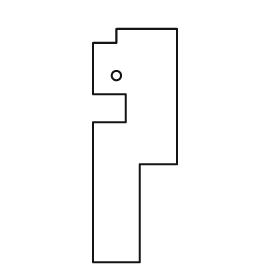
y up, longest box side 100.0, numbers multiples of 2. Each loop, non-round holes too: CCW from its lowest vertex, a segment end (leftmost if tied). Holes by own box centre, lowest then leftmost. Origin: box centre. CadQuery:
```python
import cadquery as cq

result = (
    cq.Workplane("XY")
    .moveTo(-18.0, -50.0)
    .lineTo(2.0, -50.0)
    .lineTo(2.0, -8.0)
    .lineTo(18.0, -8.0)
    .lineTo(18.0, 50.0)
    .lineTo(-8.0, 50.0)
    .lineTo(-8.0, 44.0)
    .lineTo(-18.0, 44.0)
    .lineTo(-18.0, 22.0)
    .lineTo(-4.0, 22.0)
    .lineTo(-4.0, 10.0)
    .lineTo(-18.0, 10.0)
    .close()
    .moveTo(-8.0, 30.0)
    .circle(2.0)
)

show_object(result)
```